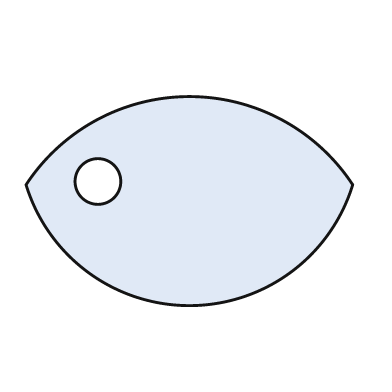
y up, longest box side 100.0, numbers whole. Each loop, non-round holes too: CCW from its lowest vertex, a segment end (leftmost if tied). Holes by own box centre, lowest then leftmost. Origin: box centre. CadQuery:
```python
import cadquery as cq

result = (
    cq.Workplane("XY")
    .moveTo(-50.0, 5.0)
    .threePointArc((0.0, -32.0), (50.0, 5.0))
    .threePointArc((0.0, 32.0), (-50.0, 5.0))
    .close()
    .moveTo(-28.0, 6.0)
    .circle(7.0)
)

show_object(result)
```